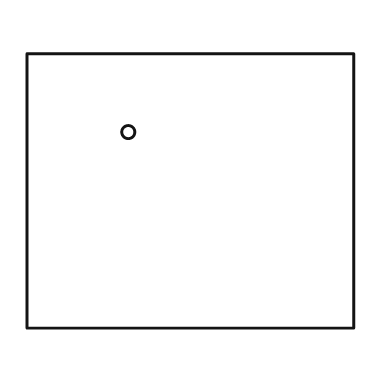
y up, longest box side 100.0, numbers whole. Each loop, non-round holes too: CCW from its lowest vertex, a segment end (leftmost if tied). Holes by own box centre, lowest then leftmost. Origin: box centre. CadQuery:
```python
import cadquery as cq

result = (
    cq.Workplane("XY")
    .moveTo(-50.0, -42.0)
    .lineTo(50.0, -42.0)
    .lineTo(50.0, 42.0)
    .lineTo(-50.0, 42.0)
    .close()
    .moveTo(-19.0, 18.0)
    .circle(2.0)
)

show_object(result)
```